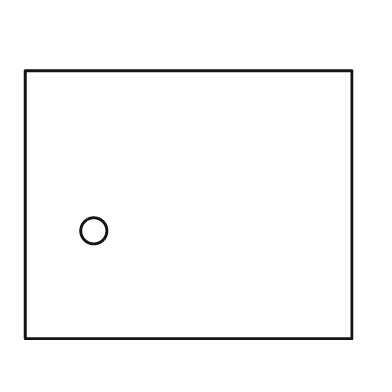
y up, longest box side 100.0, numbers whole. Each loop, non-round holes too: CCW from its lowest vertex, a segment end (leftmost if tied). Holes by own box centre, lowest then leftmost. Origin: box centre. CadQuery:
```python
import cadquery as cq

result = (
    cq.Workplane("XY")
    .moveTo(-50.0, -41.0)
    .lineTo(50.0, -41.0)
    .lineTo(50.0, 41.0)
    .lineTo(-50.0, 41.0)
    .close()
    .moveTo(-29.0, -8.0)
    .circle(4.0)
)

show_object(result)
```